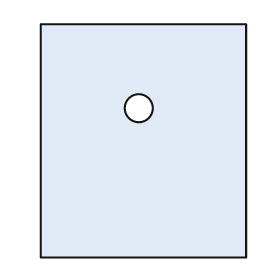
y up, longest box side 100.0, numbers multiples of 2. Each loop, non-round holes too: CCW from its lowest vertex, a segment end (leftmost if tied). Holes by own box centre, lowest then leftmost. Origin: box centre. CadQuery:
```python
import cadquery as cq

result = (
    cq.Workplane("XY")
    .moveTo(-44.0, -50.0)
    .lineTo(44.0, -50.0)
    .lineTo(44.0, 50.0)
    .lineTo(-44.0, 50.0)
    .close()
    .moveTo(-2.0, 14.0)
    .circle(6.0)
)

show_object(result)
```